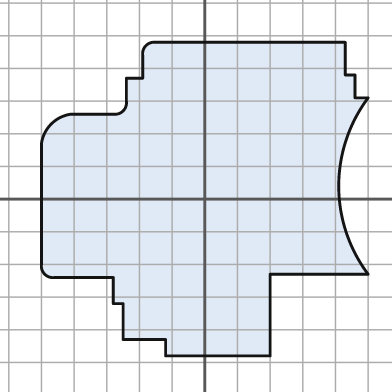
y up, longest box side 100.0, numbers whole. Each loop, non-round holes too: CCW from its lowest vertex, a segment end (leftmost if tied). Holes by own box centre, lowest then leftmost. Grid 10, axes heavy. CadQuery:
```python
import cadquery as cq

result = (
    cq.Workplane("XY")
    .moveTo(-12.0, -48.0)
    .lineTo(20.0, -48.0)
    .lineTo(20.0, -23.0)
    .lineTo(50.0, -23.0)
    .threePointArc((41.0, 4.0), (50.0, 31.0))
    .lineTo(46.0, 31.0)
    .lineTo(46.0, 38.0)
    .lineTo(43.0, 38.0)
    .lineTo(43.0, 48.0)
    .lineTo(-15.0, 48.0)
    .threePointArc((-18.0, 47.0), (-19.0, 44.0))
    .lineTo(-19.0, 37.0)
    .lineTo(-24.0, 37.0)
    .lineTo(-24.0, 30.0)
    .threePointArc((-25.0, 27.0), (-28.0, 26.0))
    .lineTo(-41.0, 26.0)
    .threePointArc((-47.0, 23.0), (-50.0, 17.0))
    .lineTo(-50.0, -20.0)
    .threePointArc((-49.0, -23.0), (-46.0, -24.0))
    .lineTo(-28.0, -24.0)
    .lineTo(-28.0, -32.0)
    .lineTo(-25.0, -32.0)
    .lineTo(-25.0, -43.0)
    .lineTo(-12.0, -43.0)
    .close()
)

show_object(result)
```